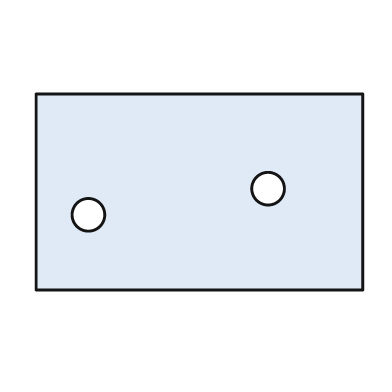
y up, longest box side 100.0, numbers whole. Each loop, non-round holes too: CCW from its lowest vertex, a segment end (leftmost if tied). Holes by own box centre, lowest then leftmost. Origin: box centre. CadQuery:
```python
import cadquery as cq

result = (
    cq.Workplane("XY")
    .moveTo(-50.0, -30.0)
    .lineTo(50.0, -30.0)
    .lineTo(50.0, 30.0)
    .lineTo(-50.0, 30.0)
    .close()
    .moveTo(-34.0, -7.0)
    .circle(5.0)
    .moveTo(21.0, 1.0)
    .circle(5.0)
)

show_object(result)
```